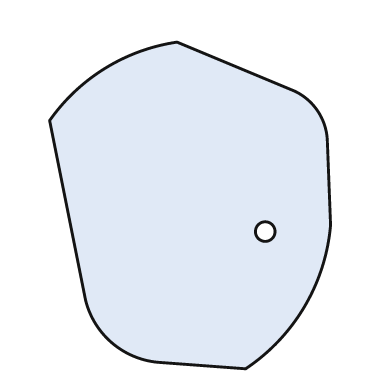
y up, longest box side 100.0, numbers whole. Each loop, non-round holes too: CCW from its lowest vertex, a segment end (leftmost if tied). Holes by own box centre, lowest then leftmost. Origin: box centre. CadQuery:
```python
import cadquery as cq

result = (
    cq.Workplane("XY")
    .moveTo(17.0, -50.0)
    .threePointArc((35.0, -31.0), (43.0, -6.0))
    .lineTo(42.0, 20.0)
    .threePointArc((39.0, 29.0), (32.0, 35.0))
    .lineTo(-4.0, 50.0)
    .threePointArc((-26.0, 42.0), (-43.0, 26.0))
    .lineTo(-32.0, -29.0)
    .threePointArc((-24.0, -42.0), (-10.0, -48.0))
    .close()
    .moveTo(23.0, -8.0)
    .circle(3.0)
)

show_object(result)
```